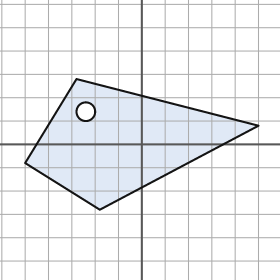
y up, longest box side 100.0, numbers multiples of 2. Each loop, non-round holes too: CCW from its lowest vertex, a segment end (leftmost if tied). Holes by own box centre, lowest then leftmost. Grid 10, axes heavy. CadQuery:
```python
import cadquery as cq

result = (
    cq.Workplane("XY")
    .moveTo(-18.0, -28.0)
    .lineTo(50.0, 8.0)
    .lineTo(-28.0, 28.0)
    .lineTo(-50.0, -8.0)
    .close()
    .moveTo(-24.0, 14.0)
    .circle(4.0)
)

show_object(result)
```